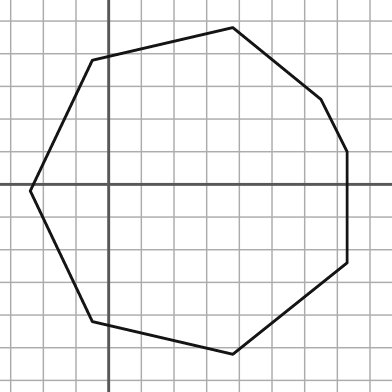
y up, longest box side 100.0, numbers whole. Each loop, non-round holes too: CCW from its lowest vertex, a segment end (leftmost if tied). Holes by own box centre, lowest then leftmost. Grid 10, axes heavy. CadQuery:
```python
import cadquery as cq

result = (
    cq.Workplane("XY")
    .moveTo(38.0, -52.0)
    .lineTo(73.0, -24.0)
    .lineTo(73.0, 10.0)
    .lineTo(65.0, 26.0)
    .lineTo(38.0, 48.0)
    .lineTo(-5.0, 38.0)
    .lineTo(-24.0, -2.0)
    .lineTo(-5.0, -42.0)
    .close()
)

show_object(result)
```